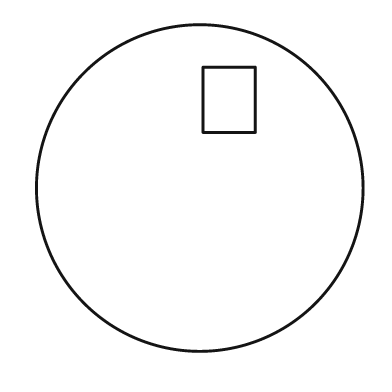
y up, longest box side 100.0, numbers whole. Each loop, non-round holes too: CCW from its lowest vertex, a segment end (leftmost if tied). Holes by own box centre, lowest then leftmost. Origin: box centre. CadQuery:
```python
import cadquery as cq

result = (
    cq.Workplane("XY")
    .moveTo(0.0, 0.0)
    .circle(50.0)
    .moveTo(1.0, 17.0)
    .lineTo(17.0, 17.0)
    .lineTo(17.0, 37.0)
    .lineTo(1.0, 37.0)
    .close()
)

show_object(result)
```